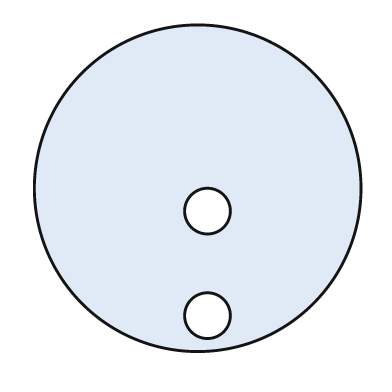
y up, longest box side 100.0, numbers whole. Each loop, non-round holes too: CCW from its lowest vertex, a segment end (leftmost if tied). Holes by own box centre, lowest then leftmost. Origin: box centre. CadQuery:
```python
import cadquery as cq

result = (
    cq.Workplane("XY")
    .moveTo(0.0, 0.0)
    .circle(50.0)
    .moveTo(3.0, -39.0)
    .circle(7.0)
    .moveTo(3.0, -7.0)
    .circle(7.0)
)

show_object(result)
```